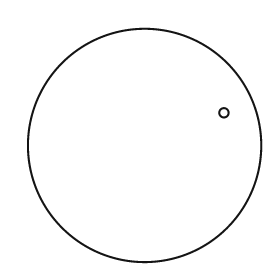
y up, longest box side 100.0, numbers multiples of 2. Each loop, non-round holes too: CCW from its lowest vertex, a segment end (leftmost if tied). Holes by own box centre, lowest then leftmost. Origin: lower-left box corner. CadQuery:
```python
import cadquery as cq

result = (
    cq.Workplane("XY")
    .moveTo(50.0, 50.0)
    .circle(50.0)
    .moveTo(84.0, 64.0)
    .circle(2.0)
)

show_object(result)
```